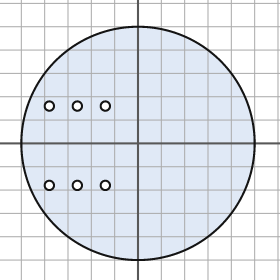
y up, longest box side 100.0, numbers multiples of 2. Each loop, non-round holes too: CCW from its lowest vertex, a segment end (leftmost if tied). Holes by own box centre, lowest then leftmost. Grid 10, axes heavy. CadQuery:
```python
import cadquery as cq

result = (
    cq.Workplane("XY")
    .moveTo(0.0, 0.0)
    .circle(50.0)
    .moveTo(-38.0, -18.0)
    .circle(2.0)
    .moveTo(-26.0, -18.0)
    .circle(2.0)
    .moveTo(-14.0, -18.0)
    .circle(2.0)
    .moveTo(-38.0, 16.0)
    .circle(2.0)
    .moveTo(-26.0, 16.0)
    .circle(2.0)
    .moveTo(-14.0, 16.0)
    .circle(2.0)
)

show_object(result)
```